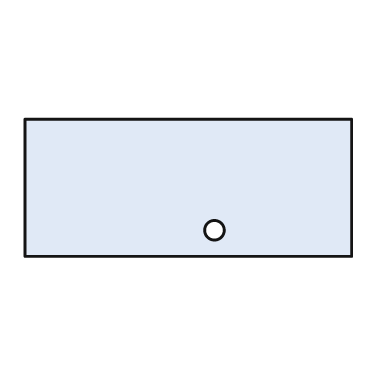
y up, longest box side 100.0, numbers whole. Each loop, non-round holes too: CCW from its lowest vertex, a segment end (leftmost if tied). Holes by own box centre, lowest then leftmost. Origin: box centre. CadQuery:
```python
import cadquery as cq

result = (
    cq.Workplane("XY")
    .moveTo(-50.0, -21.0)
    .lineTo(50.0, -21.0)
    .lineTo(50.0, 21.0)
    .lineTo(-50.0, 21.0)
    .close()
    .moveTo(8.0, -13.0)
    .circle(3.0)
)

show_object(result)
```